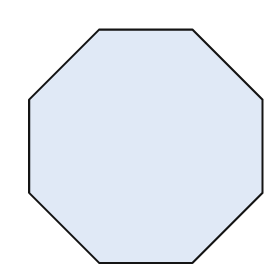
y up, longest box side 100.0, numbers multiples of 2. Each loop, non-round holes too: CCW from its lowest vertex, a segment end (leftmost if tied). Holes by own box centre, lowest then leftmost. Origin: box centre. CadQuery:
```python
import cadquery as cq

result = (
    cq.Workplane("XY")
    .moveTo(-20.0, -50.0)
    .lineTo(20.0, -50.0)
    .lineTo(50.0, -20.0)
    .lineTo(50.0, 20.0)
    .lineTo(20.0, 50.0)
    .lineTo(-20.0, 50.0)
    .lineTo(-50.0, 20.0)
    .lineTo(-50.0, -20.0)
    .close()
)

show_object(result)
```